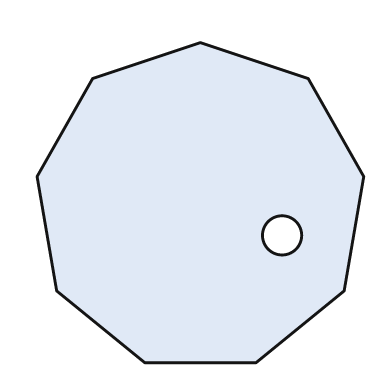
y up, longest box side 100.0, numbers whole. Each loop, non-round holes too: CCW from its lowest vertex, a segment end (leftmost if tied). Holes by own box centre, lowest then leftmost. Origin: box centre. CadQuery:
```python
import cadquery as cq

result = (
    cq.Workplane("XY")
    .moveTo(-17.0, -49.0)
    .lineTo(17.0, -49.0)
    .lineTo(44.0, -27.0)
    .lineTo(50.0, 8.0)
    .lineTo(33.0, 38.0)
    .lineTo(0.0, 49.0)
    .lineTo(-33.0, 38.0)
    .lineTo(-50.0, 8.0)
    .lineTo(-44.0, -27.0)
    .close()
    .moveTo(25.0, -10.0)
    .circle(6.0)
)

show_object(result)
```